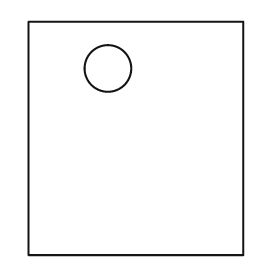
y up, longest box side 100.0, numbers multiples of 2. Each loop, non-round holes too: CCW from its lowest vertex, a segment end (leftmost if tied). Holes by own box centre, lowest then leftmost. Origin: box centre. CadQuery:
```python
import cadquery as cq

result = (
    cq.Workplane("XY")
    .moveTo(-46.0, -50.0)
    .lineTo(46.0, -50.0)
    .lineTo(46.0, 50.0)
    .lineTo(-46.0, 50.0)
    .close()
    .moveTo(-12.0, 30.0)
    .circle(10.0)
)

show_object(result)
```